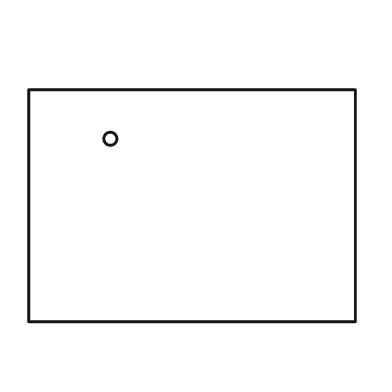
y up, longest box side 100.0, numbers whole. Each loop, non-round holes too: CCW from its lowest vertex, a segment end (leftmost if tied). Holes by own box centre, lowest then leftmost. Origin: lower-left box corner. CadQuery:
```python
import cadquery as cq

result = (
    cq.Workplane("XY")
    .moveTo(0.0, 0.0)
    .lineTo(100.0, 0.0)
    .lineTo(100.0, 71.0)
    .lineTo(0.0, 71.0)
    .close()
    .moveTo(25.0, 56.0)
    .circle(2.0)
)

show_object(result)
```